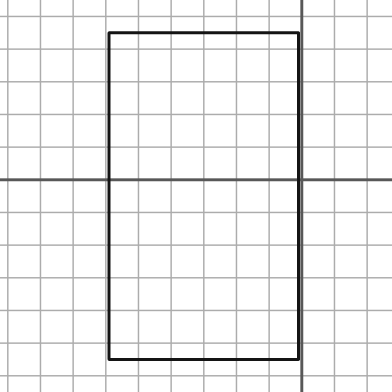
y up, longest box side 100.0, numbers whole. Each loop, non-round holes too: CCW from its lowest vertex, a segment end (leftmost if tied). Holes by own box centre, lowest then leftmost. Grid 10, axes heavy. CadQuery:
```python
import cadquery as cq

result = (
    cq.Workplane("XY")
    .moveTo(-59.0, -55.0)
    .lineTo(-1.0, -55.0)
    .lineTo(-1.0, 45.0)
    .lineTo(-59.0, 45.0)
    .close()
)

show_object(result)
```